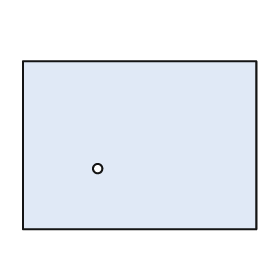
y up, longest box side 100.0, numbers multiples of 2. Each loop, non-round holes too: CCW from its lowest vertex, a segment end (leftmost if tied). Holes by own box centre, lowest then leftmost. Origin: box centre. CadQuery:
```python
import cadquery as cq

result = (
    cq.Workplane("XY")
    .moveTo(-50.0, -36.0)
    .lineTo(50.0, -36.0)
    .lineTo(50.0, 36.0)
    .lineTo(-50.0, 36.0)
    .close()
    .moveTo(-18.0, -10.0)
    .circle(2.0)
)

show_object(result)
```